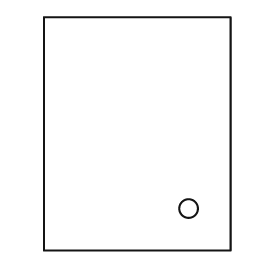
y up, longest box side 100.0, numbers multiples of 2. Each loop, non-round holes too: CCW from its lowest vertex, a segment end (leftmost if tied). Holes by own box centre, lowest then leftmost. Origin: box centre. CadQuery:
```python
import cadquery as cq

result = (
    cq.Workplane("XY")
    .moveTo(-40.0, -50.0)
    .lineTo(40.0, -50.0)
    .lineTo(40.0, 50.0)
    .lineTo(-40.0, 50.0)
    .close()
    .moveTo(22.0, -32.0)
    .circle(4.0)
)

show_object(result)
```